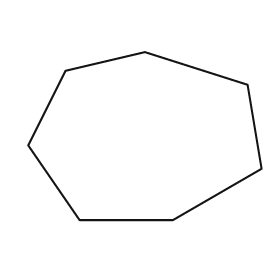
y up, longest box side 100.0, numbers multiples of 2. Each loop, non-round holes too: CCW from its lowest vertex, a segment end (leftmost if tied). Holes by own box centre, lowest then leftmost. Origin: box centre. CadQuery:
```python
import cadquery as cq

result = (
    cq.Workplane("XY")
    .moveTo(-28.0, -36.0)
    .lineTo(12.0, -36.0)
    .lineTo(50.0, -14.0)
    .lineTo(44.0, 22.0)
    .lineTo(0.0, 36.0)
    .lineTo(-34.0, 28.0)
    .lineTo(-50.0, -4.0)
    .close()
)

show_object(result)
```